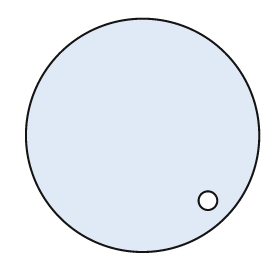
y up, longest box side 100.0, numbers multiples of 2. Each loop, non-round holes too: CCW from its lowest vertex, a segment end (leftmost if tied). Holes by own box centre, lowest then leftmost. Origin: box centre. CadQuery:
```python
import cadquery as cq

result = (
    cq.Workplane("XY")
    .moveTo(0.0, 0.0)
    .circle(50.0)
    .moveTo(28.0, -28.0)
    .circle(4.0)
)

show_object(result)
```